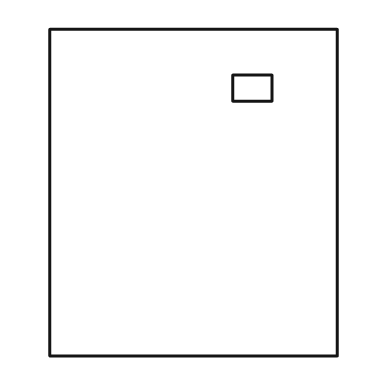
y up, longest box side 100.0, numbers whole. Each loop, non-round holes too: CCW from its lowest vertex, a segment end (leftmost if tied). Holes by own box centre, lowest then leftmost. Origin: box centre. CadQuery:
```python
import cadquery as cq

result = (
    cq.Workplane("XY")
    .moveTo(-44.0, -50.0)
    .lineTo(44.0, -50.0)
    .lineTo(44.0, 50.0)
    .lineTo(-44.0, 50.0)
    .close()
    .moveTo(12.0, 28.0)
    .lineTo(24.0, 28.0)
    .lineTo(24.0, 36.0)
    .lineTo(12.0, 36.0)
    .close()
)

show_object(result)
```